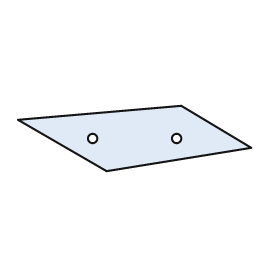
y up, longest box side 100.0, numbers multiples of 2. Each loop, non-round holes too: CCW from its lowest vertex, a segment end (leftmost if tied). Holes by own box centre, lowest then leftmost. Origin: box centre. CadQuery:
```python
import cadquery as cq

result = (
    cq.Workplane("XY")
    .moveTo(-12.0, -14.0)
    .lineTo(50.0, -4.0)
    .lineTo(20.0, 14.0)
    .lineTo(-50.0, 8.0)
    .close()
    .moveTo(-18.0, 0.0)
    .circle(2.0)
    .moveTo(18.0, 0.0)
    .circle(2.0)
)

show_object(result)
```